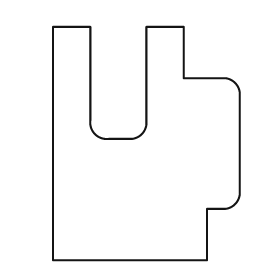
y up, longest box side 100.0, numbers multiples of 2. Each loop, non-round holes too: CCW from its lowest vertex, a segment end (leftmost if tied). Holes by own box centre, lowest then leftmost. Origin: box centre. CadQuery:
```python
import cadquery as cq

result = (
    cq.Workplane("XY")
    .moveTo(-40.0, -50.0)
    .lineTo(26.0, -50.0)
    .lineTo(26.0, -28.0)
    .lineTo(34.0, -28.0)
    .threePointArc((38.0, -26.0), (40.0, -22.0))
    .lineTo(40.0, 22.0)
    .threePointArc((38.0, 26.0), (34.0, 28.0))
    .lineTo(16.0, 28.0)
    .lineTo(16.0, 50.0)
    .lineTo(0.0, 50.0)
    .lineTo(0.0, 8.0)
    .threePointArc((-2.0, 4.0), (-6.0, 2.0))
    .lineTo(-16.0, 2.0)
    .threePointArc((-22.0, 4.0), (-24.0, 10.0))
    .lineTo(-24.0, 50.0)
    .lineTo(-40.0, 50.0)
    .close()
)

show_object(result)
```